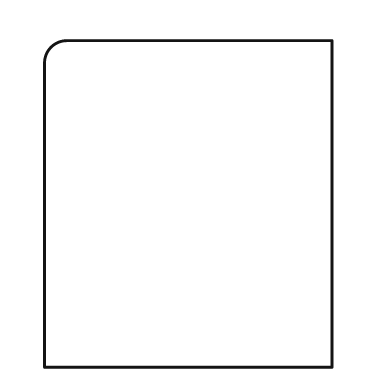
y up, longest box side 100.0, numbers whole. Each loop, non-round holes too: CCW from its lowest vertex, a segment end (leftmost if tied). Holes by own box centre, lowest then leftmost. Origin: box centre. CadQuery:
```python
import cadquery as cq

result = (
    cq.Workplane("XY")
    .moveTo(-44.0, -50.0)
    .lineTo(44.0, -50.0)
    .lineTo(44.0, 50.0)
    .lineTo(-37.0, 50.0)
    .threePointArc((-42.0, 48.0), (-44.0, 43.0))
    .close()
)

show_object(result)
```